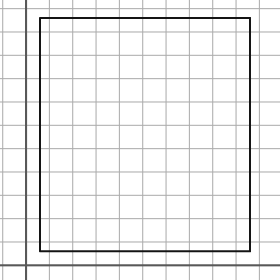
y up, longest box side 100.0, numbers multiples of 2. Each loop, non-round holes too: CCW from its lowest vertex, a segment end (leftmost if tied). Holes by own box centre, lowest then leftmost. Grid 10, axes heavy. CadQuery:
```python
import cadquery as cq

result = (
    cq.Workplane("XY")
    .moveTo(6.0, 6.0)
    .lineTo(96.0, 6.0)
    .lineTo(96.0, 106.0)
    .lineTo(6.0, 106.0)
    .close()
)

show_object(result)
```